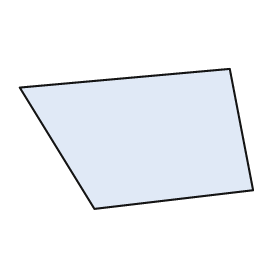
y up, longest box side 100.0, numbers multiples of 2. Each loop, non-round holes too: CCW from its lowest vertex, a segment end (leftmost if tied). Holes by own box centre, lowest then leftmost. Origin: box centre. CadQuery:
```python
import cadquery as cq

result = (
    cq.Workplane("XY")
    .moveTo(-18.0, -30.0)
    .lineTo(50.0, -22.0)
    .lineTo(40.0, 30.0)
    .lineTo(-50.0, 22.0)
    .close()
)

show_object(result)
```